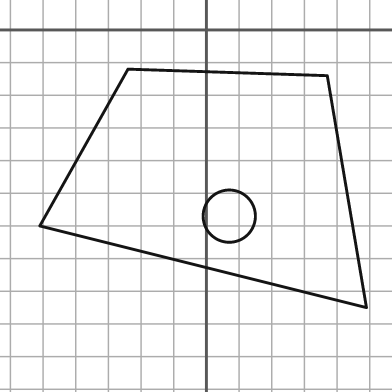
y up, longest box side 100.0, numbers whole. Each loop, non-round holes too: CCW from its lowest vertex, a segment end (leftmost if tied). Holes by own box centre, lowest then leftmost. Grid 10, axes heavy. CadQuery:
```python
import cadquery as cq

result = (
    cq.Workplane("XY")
    .moveTo(49.0, -85.0)
    .lineTo(37.0, -14.0)
    .lineTo(-24.0, -12.0)
    .lineTo(-51.0, -60.0)
    .close()
    .moveTo(7.0, -57.0)
    .circle(8.0)
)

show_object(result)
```